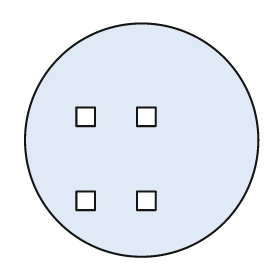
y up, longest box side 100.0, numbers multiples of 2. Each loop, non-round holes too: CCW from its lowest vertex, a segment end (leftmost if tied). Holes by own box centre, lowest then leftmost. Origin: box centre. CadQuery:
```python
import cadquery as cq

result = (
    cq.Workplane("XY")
    .moveTo(0.0, 0.0)
    .circle(50.0)
    .moveTo(-28.0, -30.0)
    .lineTo(-20.0, -30.0)
    .lineTo(-20.0, -22.0)
    .lineTo(-28.0, -22.0)
    .close()
    .moveTo(-2.0, -30.0)
    .lineTo(6.0, -30.0)
    .lineTo(6.0, -22.0)
    .lineTo(-2.0, -22.0)
    .close()
    .moveTo(-28.0, 6.0)
    .lineTo(-20.0, 6.0)
    .lineTo(-20.0, 14.0)
    .lineTo(-28.0, 14.0)
    .close()
    .moveTo(-2.0, 6.0)
    .lineTo(6.0, 6.0)
    .lineTo(6.0, 14.0)
    .lineTo(-2.0, 14.0)
    .close()
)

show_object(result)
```